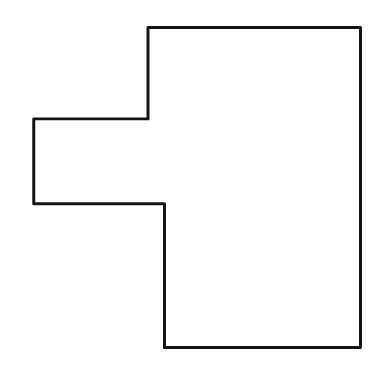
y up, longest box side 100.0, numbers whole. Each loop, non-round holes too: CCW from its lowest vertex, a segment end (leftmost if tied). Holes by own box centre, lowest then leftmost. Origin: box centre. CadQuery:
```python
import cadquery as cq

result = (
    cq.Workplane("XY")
    .moveTo(-10.0, -49.0)
    .lineTo(50.0, -49.0)
    .lineTo(50.0, 49.0)
    .lineTo(-15.0, 49.0)
    .lineTo(-15.0, 21.0)
    .lineTo(-50.0, 21.0)
    .lineTo(-50.0, -5.0)
    .lineTo(-10.0, -5.0)
    .close()
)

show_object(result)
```